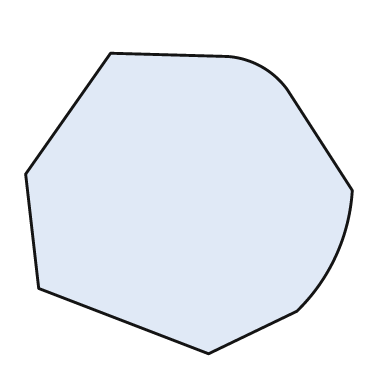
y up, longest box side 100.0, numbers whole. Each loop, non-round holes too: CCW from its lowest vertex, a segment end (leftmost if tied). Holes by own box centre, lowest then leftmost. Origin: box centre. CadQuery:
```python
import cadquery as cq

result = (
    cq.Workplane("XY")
    .moveTo(6.0, -46.0)
    .lineTo(33.0, -33.0)
    .threePointArc((45.0, -16.0), (50.0, 4.0))
    .lineTo(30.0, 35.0)
    .threePointArc((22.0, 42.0), (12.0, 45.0))
    .lineTo(-24.0, 46.0)
    .lineTo(-50.0, 9.0)
    .lineTo(-46.0, -26.0)
    .close()
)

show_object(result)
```